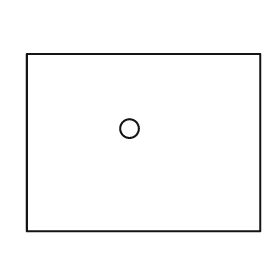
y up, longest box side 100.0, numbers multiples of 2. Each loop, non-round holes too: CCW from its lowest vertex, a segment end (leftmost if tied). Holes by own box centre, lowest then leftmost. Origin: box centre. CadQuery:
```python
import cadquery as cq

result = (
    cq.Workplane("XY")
    .moveTo(-50.0, -38.0)
    .lineTo(50.0, -38.0)
    .lineTo(50.0, 38.0)
    .lineTo(-50.0, 38.0)
    .close()
    .moveTo(-6.0, 6.0)
    .circle(4.0)
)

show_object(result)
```